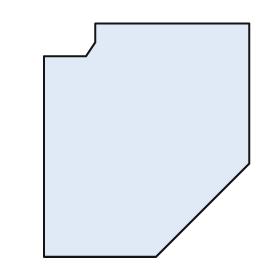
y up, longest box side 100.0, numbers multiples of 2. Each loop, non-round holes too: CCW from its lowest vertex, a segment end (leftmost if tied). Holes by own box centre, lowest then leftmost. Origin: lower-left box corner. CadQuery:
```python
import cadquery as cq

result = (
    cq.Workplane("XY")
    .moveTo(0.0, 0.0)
    .lineTo(48.0, 0.0)
    .lineTo(88.0, 40.0)
    .lineTo(88.0, 100.0)
    .lineTo(22.0, 100.0)
    .lineTo(22.0, 92.0)
    .lineTo(18.0, 86.0)
    .lineTo(0.0, 86.0)
    .close()
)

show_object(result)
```